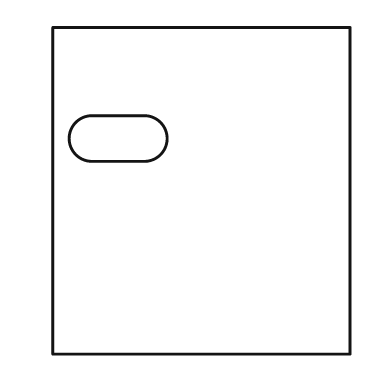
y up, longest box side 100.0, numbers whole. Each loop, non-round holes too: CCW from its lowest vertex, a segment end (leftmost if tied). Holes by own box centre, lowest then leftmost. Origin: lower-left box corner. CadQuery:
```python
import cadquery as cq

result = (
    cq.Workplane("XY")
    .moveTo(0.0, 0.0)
    .lineTo(91.0, 0.0)
    .lineTo(91.0, 100.0)
    .lineTo(0.0, 100.0)
    .close()
    .moveTo(12.0, 59.0)
    .lineTo(28.0, 59.0)
    .threePointArc((35.0, 66.0), (28.0, 73.0))
    .lineTo(12.0, 73.0)
    .threePointArc((5.0, 66.0), (12.0, 59.0))
    .close()
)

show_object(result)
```